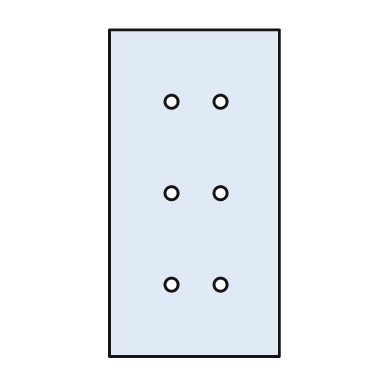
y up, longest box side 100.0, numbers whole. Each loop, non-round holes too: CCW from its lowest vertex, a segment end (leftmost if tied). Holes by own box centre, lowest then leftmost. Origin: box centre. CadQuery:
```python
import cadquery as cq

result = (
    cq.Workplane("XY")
    .moveTo(-26.0, -50.0)
    .lineTo(26.0, -50.0)
    .lineTo(26.0, 50.0)
    .lineTo(-26.0, 50.0)
    .close()
    .moveTo(-7.0, -28.0)
    .circle(2.0)
    .moveTo(8.0, -28.0)
    .circle(2.0)
    .moveTo(-7.0, 0.0)
    .circle(2.0)
    .moveTo(8.0, 0.0)
    .circle(2.0)
    .moveTo(-7.0, 28.0)
    .circle(2.0)
    .moveTo(8.0, 28.0)
    .circle(2.0)
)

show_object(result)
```